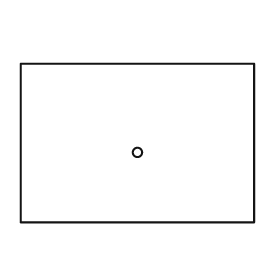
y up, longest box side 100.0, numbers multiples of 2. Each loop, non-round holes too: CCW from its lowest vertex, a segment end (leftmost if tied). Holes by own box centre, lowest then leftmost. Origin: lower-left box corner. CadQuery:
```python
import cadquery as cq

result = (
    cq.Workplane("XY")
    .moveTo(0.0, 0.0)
    .lineTo(100.0, 0.0)
    .lineTo(100.0, 68.0)
    .lineTo(0.0, 68.0)
    .close()
    .moveTo(50.0, 30.0)
    .circle(2.0)
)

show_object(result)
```